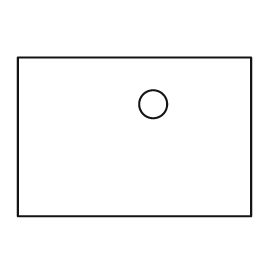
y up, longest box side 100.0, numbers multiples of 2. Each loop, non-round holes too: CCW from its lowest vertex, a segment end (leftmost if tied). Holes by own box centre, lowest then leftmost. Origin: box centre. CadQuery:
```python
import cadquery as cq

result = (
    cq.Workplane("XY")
    .moveTo(-50.0, -34.0)
    .lineTo(50.0, -34.0)
    .lineTo(50.0, 34.0)
    .lineTo(-50.0, 34.0)
    .close()
    .moveTo(8.0, 14.0)
    .circle(6.0)
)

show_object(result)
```